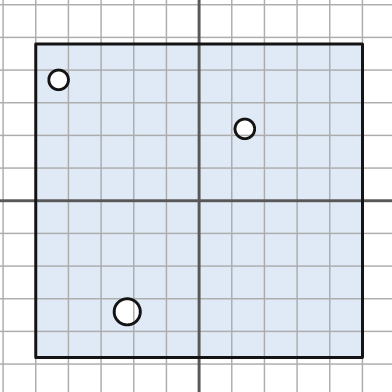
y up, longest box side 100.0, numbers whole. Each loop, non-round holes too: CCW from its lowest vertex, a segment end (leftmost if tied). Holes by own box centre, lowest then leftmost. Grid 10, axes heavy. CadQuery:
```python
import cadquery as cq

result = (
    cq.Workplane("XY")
    .moveTo(-50.0, -48.0)
    .lineTo(50.0, -48.0)
    .lineTo(50.0, 48.0)
    .lineTo(-50.0, 48.0)
    .close()
    .moveTo(-22.0, -34.0)
    .circle(4.0)
    .moveTo(14.0, 22.0)
    .circle(3.0)
    .moveTo(-43.0, 37.0)
    .circle(3.0)
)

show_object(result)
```